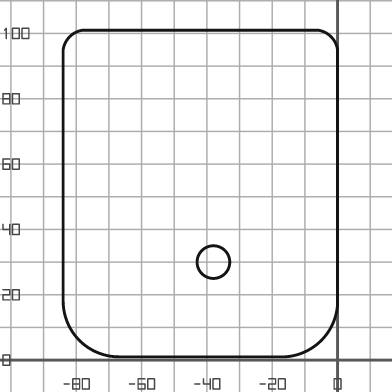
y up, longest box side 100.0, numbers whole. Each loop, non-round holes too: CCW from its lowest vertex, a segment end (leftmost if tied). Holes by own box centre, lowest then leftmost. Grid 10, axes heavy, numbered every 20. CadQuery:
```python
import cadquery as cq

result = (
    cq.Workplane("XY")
    .moveTo(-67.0, 1.0)
    .lineTo(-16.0, 1.0)
    .threePointArc((-5.0, 6.0), (0.0, 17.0))
    .lineTo(0.0, 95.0)
    .threePointArc((-2.0, 99.0), (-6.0, 101.0))
    .lineTo(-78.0, 101.0)
    .threePointArc((-82.0, 99.0), (-84.0, 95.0))
    .lineTo(-84.0, 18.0)
    .threePointArc((-79.0, 6.0), (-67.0, 1.0))
    .close()
    .moveTo(-38.0, 30.0)
    .circle(5.0)
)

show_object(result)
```